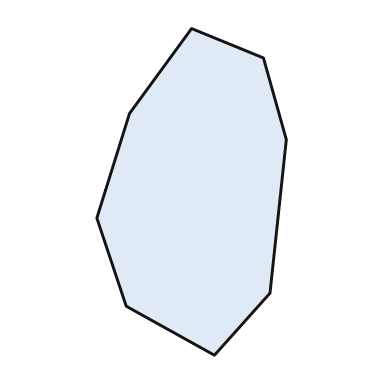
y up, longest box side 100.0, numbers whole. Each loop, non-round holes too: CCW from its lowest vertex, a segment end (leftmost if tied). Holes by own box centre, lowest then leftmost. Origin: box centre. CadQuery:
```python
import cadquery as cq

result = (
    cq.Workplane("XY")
    .moveTo(7.0, -50.0)
    .lineTo(24.0, -31.0)
    .lineTo(29.0, 16.0)
    .lineTo(22.0, 41.0)
    .lineTo(0.0, 50.0)
    .lineTo(-19.0, 24.0)
    .lineTo(-29.0, -8.0)
    .lineTo(-20.0, -35.0)
    .close()
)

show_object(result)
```